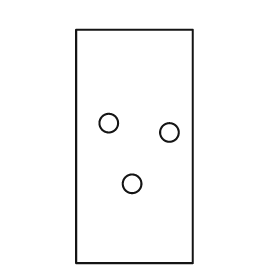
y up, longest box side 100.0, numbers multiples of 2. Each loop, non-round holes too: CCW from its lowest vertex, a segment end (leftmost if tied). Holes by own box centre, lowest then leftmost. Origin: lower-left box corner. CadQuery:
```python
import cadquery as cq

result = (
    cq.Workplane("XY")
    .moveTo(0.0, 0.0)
    .lineTo(50.0, 0.0)
    .lineTo(50.0, 100.0)
    .lineTo(0.0, 100.0)
    .close()
    .moveTo(24.0, 34.0)
    .circle(4.0)
    .moveTo(40.0, 56.0)
    .circle(4.0)
    .moveTo(14.0, 60.0)
    .circle(4.0)
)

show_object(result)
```